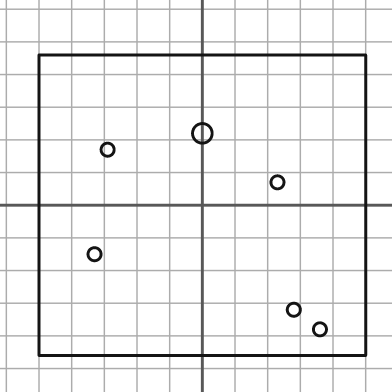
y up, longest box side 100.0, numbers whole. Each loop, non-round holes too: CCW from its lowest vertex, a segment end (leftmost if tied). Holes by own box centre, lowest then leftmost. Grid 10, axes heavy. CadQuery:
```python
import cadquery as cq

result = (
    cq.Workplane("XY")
    .moveTo(-50.0, -46.0)
    .lineTo(50.0, -46.0)
    .lineTo(50.0, 46.0)
    .lineTo(-50.0, 46.0)
    .close()
    .moveTo(36.0, -38.0)
    .circle(2.0)
    .moveTo(28.0, -32.0)
    .circle(2.0)
    .moveTo(-33.0, -15.0)
    .circle(2.0)
    .moveTo(23.0, 7.0)
    .circle(2.0)
    .moveTo(-29.0, 17.0)
    .circle(2.0)
    .moveTo(0.0, 22.0)
    .circle(3.0)
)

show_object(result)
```